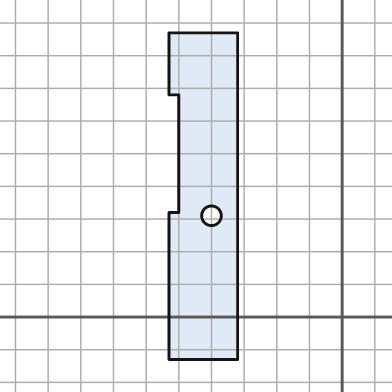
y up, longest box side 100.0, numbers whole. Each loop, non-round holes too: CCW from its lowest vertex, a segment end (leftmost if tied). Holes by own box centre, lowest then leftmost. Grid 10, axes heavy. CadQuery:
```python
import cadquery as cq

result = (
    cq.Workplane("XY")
    .moveTo(-53.0, -13.0)
    .lineTo(-32.0, -13.0)
    .lineTo(-32.0, 87.0)
    .lineTo(-53.0, 87.0)
    .lineTo(-53.0, 68.0)
    .lineTo(-50.0, 68.0)
    .lineTo(-50.0, 32.0)
    .lineTo(-53.0, 32.0)
    .close()
    .moveTo(-40.0, 31.0)
    .circle(3.0)
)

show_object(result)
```